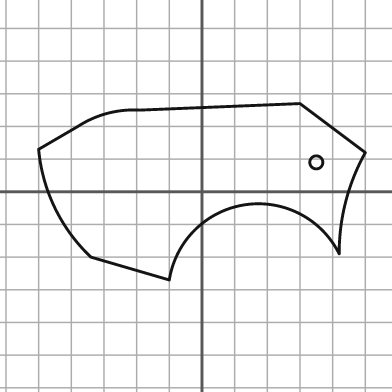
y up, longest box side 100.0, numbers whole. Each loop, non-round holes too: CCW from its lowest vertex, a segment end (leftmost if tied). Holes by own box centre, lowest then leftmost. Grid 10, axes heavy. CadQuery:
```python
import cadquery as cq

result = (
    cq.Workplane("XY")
    .moveTo(-10.0, -27.0)
    .threePointArc((13.0, -4.0), (42.0, -19.0))
    .threePointArc((44.0, -3.0), (50.0, 12.0))
    .lineTo(30.0, 27.0)
    .lineTo(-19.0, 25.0)
    .threePointArc((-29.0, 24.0), (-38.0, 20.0))
    .lineTo(-50.0, 13.0)
    .threePointArc((-45.0, -5.0), (-34.0, -20.0))
    .close()
    .moveTo(35.0, 9.0)
    .circle(2.0)
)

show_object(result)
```